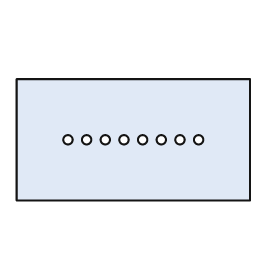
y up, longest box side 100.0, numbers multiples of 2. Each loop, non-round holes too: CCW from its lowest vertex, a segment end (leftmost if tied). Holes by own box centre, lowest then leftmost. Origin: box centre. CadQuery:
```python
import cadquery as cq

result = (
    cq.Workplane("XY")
    .moveTo(-50.0, -26.0)
    .lineTo(50.0, -26.0)
    .lineTo(50.0, 26.0)
    .lineTo(-50.0, 26.0)
    .close()
    .moveTo(-28.0, 0.0)
    .circle(2.0)
    .moveTo(-20.0, 0.0)
    .circle(2.0)
    .moveTo(-12.0, 0.0)
    .circle(2.0)
    .moveTo(-4.0, 0.0)
    .circle(2.0)
    .moveTo(4.0, 0.0)
    .circle(2.0)
    .moveTo(12.0, 0.0)
    .circle(2.0)
    .moveTo(20.0, 0.0)
    .circle(2.0)
    .moveTo(28.0, 0.0)
    .circle(2.0)
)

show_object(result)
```